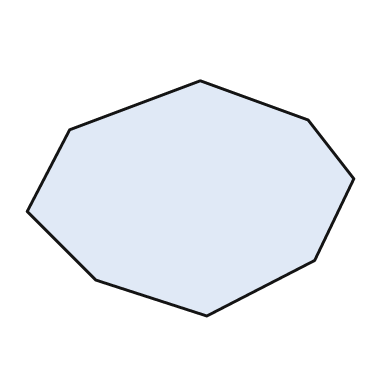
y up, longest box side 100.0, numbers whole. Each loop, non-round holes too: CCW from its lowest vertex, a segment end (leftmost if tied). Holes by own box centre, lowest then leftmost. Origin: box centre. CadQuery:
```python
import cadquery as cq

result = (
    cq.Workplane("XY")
    .moveTo(5.0, -36.0)
    .lineTo(38.0, -19.0)
    .lineTo(50.0, 6.0)
    .lineTo(36.0, 24.0)
    .lineTo(3.0, 36.0)
    .lineTo(-37.0, 21.0)
    .lineTo(-50.0, -4.0)
    .lineTo(-29.0, -25.0)
    .close()
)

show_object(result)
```